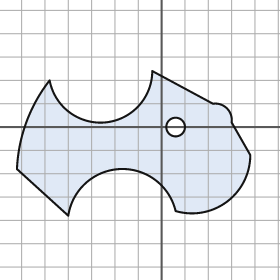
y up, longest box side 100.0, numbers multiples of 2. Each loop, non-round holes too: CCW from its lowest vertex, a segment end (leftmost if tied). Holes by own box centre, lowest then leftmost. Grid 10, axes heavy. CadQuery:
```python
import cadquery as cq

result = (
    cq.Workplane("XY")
    .moveTo(-40.0, -38.0)
    .threePointArc((-18.0, -18.0), (6.0, -36.0))
    .threePointArc((28.0, -32.0), (38.0, -12.0))
    .lineTo(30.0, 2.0)
    .threePointArc((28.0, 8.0), (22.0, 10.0))
    .lineTo(-4.0, 24.0)
    .threePointArc((-24.0, 2.0), (-48.0, 20.0))
    .threePointArc((-58.0, 2.0), (-62.0, -18.0))
    .close()
    .moveTo(6.0, 0.0)
    .circle(4.0)
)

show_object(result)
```